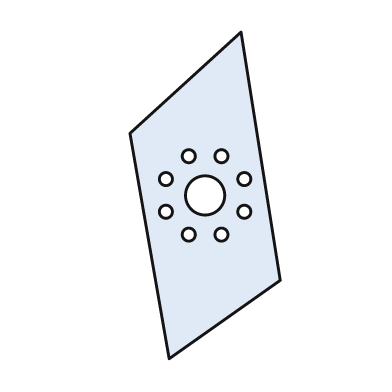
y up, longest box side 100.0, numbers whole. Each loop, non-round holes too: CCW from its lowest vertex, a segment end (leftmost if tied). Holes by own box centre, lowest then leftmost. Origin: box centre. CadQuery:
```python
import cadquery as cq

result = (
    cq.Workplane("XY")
    .moveTo(-11.0, -50.0)
    .lineTo(23.0, -26.0)
    .lineTo(11.0, 50.0)
    .lineTo(-23.0, 19.0)
    .close()
    .moveTo(-5.0, -12.0)
    .circle(2.0)
    .moveTo(5.0, -12.0)
    .circle(2.0)
    .moveTo(-12.0, -5.0)
    .circle(2.0)
    .moveTo(12.0, -5.0)
    .circle(2.0)
    .moveTo(0.0, 0.0)
    .circle(6.0)
    .moveTo(-12.0, 5.0)
    .circle(2.0)
    .moveTo(12.0, 5.0)
    .circle(2.0)
    .moveTo(-5.0, 12.0)
    .circle(2.0)
    .moveTo(5.0, 12.0)
    .circle(2.0)
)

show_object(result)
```